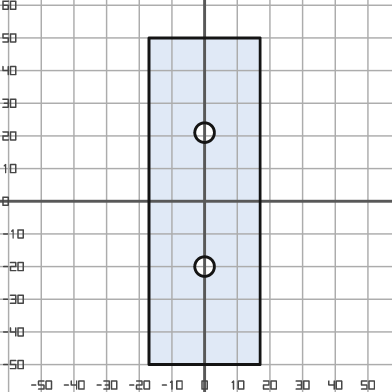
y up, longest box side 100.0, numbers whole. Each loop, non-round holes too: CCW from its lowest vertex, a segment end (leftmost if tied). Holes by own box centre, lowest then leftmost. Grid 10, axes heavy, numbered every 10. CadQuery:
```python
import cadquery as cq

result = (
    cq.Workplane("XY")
    .moveTo(-17.0, -50.0)
    .lineTo(17.0, -50.0)
    .lineTo(17.0, 50.0)
    .lineTo(-17.0, 50.0)
    .close()
    .moveTo(0.0, -20.0)
    .circle(3.0)
    .moveTo(0.0, 21.0)
    .circle(3.0)
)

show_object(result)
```